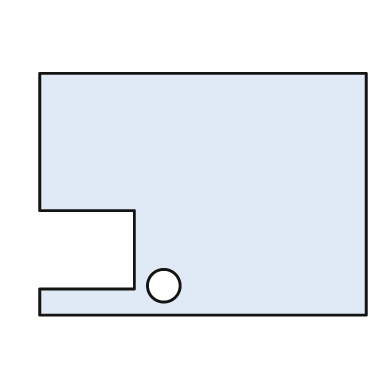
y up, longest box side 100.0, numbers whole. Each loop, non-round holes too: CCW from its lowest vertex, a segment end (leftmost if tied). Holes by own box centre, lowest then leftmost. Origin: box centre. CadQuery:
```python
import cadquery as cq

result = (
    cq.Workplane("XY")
    .moveTo(-50.0, -37.0)
    .lineTo(50.0, -37.0)
    .lineTo(50.0, 37.0)
    .lineTo(-50.0, 37.0)
    .lineTo(-50.0, -5.0)
    .lineTo(-21.0, -5.0)
    .lineTo(-21.0, -29.0)
    .lineTo(-50.0, -29.0)
    .close()
    .moveTo(-12.0, -28.0)
    .circle(5.0)
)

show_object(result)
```